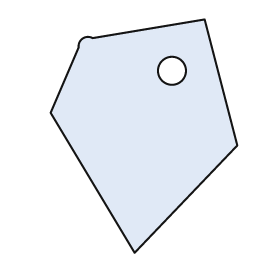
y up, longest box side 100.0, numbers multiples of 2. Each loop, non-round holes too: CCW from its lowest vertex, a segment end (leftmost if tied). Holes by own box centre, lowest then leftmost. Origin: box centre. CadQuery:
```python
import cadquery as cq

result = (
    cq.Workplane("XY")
    .moveTo(-4.0, -50.0)
    .lineTo(40.0, -4.0)
    .lineTo(26.0, 50.0)
    .lineTo(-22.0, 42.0)
    .threePointArc((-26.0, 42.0), (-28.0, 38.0))
    .lineTo(-40.0, 10.0)
    .close()
    .moveTo(12.0, 28.0)
    .circle(6.0)
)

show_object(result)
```